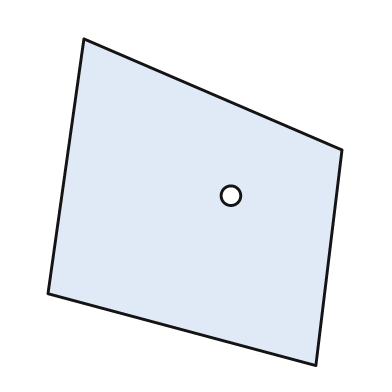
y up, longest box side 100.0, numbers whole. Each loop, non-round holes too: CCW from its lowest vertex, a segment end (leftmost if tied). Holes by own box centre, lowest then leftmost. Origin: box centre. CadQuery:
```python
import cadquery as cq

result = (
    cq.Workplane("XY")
    .moveTo(37.0, -50.0)
    .lineTo(45.0, 16.0)
    .lineTo(-34.0, 50.0)
    .lineTo(-45.0, -28.0)
    .close()
    .moveTo(11.0, 2.0)
    .circle(3.0)
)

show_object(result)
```